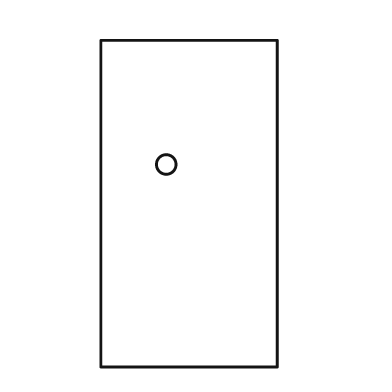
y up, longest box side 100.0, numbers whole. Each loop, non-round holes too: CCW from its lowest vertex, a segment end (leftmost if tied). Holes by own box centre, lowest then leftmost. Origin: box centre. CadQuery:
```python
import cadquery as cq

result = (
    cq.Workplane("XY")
    .moveTo(-27.0, -50.0)
    .lineTo(27.0, -50.0)
    .lineTo(27.0, 50.0)
    .lineTo(-27.0, 50.0)
    .close()
    .moveTo(-7.0, 12.0)
    .circle(3.0)
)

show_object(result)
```